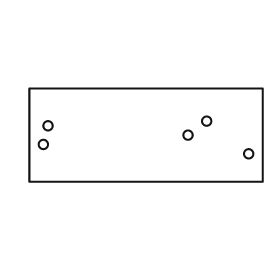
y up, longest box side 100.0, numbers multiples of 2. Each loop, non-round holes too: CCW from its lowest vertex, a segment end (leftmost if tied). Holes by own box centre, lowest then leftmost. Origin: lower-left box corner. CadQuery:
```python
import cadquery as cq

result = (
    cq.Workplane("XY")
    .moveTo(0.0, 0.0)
    .lineTo(100.0, 0.0)
    .lineTo(100.0, 40.0)
    .lineTo(0.0, 40.0)
    .close()
    .moveTo(94.0, 12.0)
    .circle(2.0)
    .moveTo(6.0, 16.0)
    .circle(2.0)
    .moveTo(68.0, 20.0)
    .circle(2.0)
    .moveTo(8.0, 24.0)
    .circle(2.0)
    .moveTo(76.0, 26.0)
    .circle(2.0)
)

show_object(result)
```